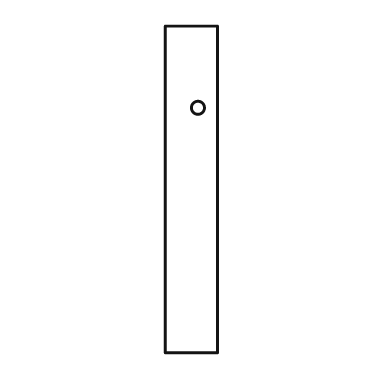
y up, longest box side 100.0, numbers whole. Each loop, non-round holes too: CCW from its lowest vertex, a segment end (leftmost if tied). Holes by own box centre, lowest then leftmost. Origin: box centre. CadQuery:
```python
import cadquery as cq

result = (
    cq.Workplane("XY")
    .moveTo(-8.0, -50.0)
    .lineTo(8.0, -50.0)
    .lineTo(8.0, 50.0)
    .lineTo(-8.0, 50.0)
    .close()
    .moveTo(2.0, 25.0)
    .circle(2.0)
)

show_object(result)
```